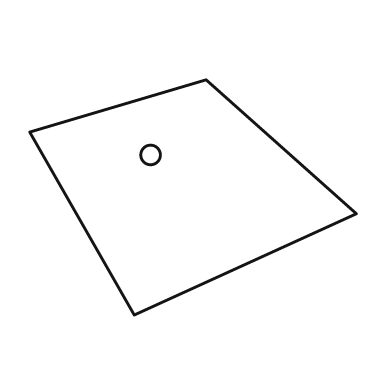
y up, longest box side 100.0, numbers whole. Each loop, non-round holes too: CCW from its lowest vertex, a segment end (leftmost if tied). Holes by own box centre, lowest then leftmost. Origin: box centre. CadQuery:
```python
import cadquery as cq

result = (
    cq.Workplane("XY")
    .moveTo(-18.0, -36.0)
    .lineTo(50.0, -5.0)
    .lineTo(4.0, 36.0)
    .lineTo(-50.0, 20.0)
    .close()
    .moveTo(-13.0, 13.0)
    .circle(3.0)
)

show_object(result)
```